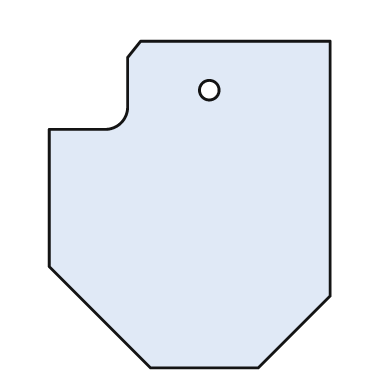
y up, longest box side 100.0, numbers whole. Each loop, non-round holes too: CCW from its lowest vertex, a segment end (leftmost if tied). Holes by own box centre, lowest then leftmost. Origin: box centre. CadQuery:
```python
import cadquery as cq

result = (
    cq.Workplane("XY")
    .moveTo(-12.0, -50.0)
    .lineTo(21.0, -50.0)
    .lineTo(43.0, -28.0)
    .lineTo(43.0, 50.0)
    .lineTo(-15.0, 50.0)
    .lineTo(-19.0, 45.0)
    .lineTo(-19.0, 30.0)
    .threePointArc((-21.0, 25.0), (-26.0, 23.0))
    .lineTo(-43.0, 23.0)
    .lineTo(-43.0, -19.0)
    .close()
    .moveTo(6.0, 35.0)
    .circle(3.0)
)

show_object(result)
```